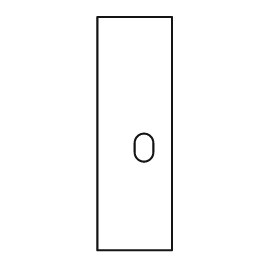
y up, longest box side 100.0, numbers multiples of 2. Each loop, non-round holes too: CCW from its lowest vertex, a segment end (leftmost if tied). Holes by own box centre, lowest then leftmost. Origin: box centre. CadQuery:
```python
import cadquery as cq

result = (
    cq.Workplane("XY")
    .moveTo(-16.0, -50.0)
    .lineTo(16.0, -50.0)
    .lineTo(16.0, 50.0)
    .lineTo(-16.0, 50.0)
    .close()
    .moveTo(0.0, -8.0)
    .threePointArc((4.0, -12.0), (8.0, -8.0))
    .lineTo(8.0, -4.0)
    .threePointArc((4.0, 0.0), (0.0, -4.0))
    .close()
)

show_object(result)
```